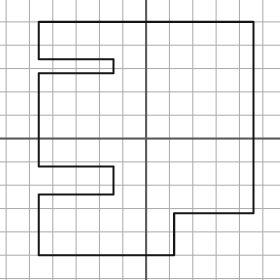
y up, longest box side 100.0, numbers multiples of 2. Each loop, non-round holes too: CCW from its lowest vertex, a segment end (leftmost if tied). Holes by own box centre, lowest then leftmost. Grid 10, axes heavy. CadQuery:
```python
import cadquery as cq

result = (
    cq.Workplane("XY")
    .moveTo(-46.0, -50.0)
    .lineTo(12.0, -50.0)
    .lineTo(12.0, -32.0)
    .lineTo(46.0, -32.0)
    .lineTo(46.0, 50.0)
    .lineTo(-46.0, 50.0)
    .lineTo(-46.0, 34.0)
    .lineTo(-14.0, 34.0)
    .lineTo(-14.0, 28.0)
    .lineTo(-46.0, 28.0)
    .lineTo(-46.0, -12.0)
    .lineTo(-14.0, -12.0)
    .lineTo(-14.0, -24.0)
    .lineTo(-46.0, -24.0)
    .close()
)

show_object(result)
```